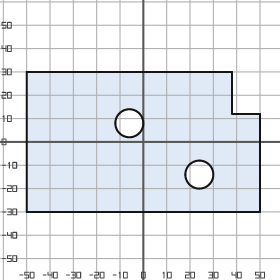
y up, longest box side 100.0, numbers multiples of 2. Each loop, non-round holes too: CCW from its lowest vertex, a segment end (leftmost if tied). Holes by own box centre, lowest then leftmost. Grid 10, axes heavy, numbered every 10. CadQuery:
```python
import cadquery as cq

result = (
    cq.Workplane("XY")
    .moveTo(-50.0, -30.0)
    .lineTo(50.0, -30.0)
    .lineTo(50.0, 12.0)
    .lineTo(38.0, 12.0)
    .lineTo(38.0, 30.0)
    .lineTo(-50.0, 30.0)
    .close()
    .moveTo(24.0, -14.0)
    .circle(6.0)
    .moveTo(-6.0, 8.0)
    .circle(6.0)
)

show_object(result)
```